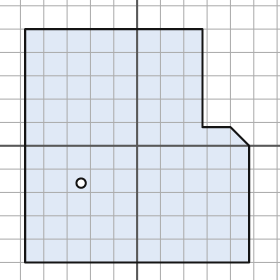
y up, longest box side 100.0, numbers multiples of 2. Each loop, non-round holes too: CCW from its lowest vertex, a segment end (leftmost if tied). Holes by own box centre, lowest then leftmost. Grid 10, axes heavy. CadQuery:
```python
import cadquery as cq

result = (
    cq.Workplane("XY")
    .moveTo(-48.0, -50.0)
    .lineTo(48.0, -50.0)
    .lineTo(48.0, 0.0)
    .lineTo(40.0, 8.0)
    .lineTo(28.0, 8.0)
    .lineTo(28.0, 50.0)
    .lineTo(-48.0, 50.0)
    .close()
    .moveTo(-24.0, -16.0)
    .circle(2.0)
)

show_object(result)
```